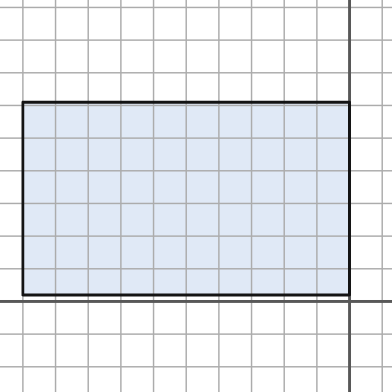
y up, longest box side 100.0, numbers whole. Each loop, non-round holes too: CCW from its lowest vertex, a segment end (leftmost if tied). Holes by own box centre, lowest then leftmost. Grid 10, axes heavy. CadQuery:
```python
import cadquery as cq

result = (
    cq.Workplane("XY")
    .moveTo(-100.0, 2.0)
    .lineTo(0.0, 2.0)
    .lineTo(0.0, 61.0)
    .lineTo(-100.0, 61.0)
    .close()
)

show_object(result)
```